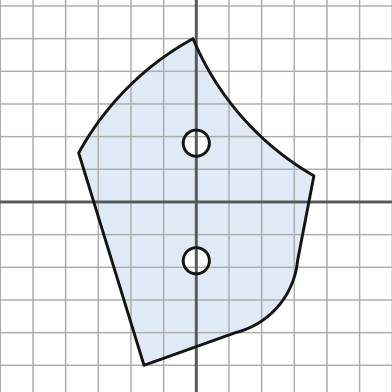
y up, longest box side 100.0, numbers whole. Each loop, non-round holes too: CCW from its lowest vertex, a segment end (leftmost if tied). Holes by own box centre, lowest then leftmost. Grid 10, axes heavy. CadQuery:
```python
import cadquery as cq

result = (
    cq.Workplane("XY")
    .moveTo(-16.0, -50.0)
    .lineTo(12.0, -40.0)
    .threePointArc((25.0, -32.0), (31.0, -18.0))
    .lineTo(36.0, 8.0)
    .threePointArc((14.0, 26.0), (-1.0, 50.0))
    .threePointArc((-21.0, 35.0), (-36.0, 15.0))
    .close()
    .moveTo(0.0, -18.0)
    .circle(4.0)
    .moveTo(0.0, 18.0)
    .circle(4.0)
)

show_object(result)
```